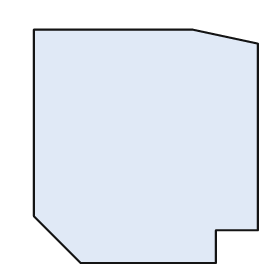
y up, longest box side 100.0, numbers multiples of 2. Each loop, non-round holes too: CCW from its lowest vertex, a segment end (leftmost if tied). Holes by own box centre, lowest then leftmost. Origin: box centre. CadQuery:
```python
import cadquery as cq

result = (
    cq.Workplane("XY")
    .moveTo(-28.0, -50.0)
    .lineTo(30.0, -50.0)
    .lineTo(30.0, -36.0)
    .lineTo(48.0, -36.0)
    .lineTo(48.0, 44.0)
    .lineTo(20.0, 50.0)
    .lineTo(-48.0, 50.0)
    .lineTo(-48.0, -30.0)
    .close()
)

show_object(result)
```